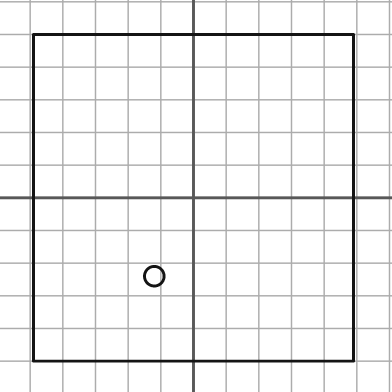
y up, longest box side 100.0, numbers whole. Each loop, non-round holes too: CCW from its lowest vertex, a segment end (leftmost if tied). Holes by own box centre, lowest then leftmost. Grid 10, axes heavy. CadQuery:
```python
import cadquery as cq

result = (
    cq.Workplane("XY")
    .moveTo(-49.0, -50.0)
    .lineTo(49.0, -50.0)
    .lineTo(49.0, 50.0)
    .lineTo(-49.0, 50.0)
    .close()
    .moveTo(-12.0, -24.0)
    .circle(3.0)
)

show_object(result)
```